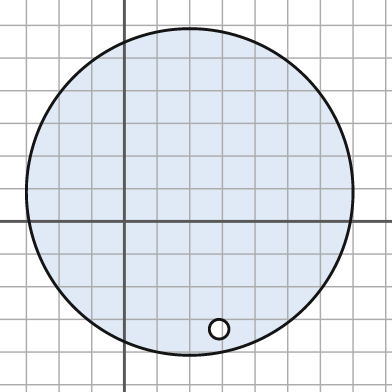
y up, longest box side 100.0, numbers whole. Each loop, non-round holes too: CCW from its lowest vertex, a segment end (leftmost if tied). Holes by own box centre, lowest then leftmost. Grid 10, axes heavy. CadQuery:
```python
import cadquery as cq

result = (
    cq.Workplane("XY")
    .moveTo(20.0, 9.0)
    .circle(50.0)
    .moveTo(29.0, -33.0)
    .circle(3.0)
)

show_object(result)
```